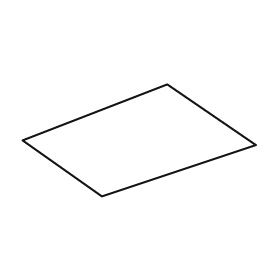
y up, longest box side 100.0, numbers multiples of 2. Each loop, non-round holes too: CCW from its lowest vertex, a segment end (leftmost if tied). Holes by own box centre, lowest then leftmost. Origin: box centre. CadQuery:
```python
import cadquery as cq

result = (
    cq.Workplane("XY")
    .moveTo(-16.0, -24.0)
    .lineTo(50.0, -2.0)
    .lineTo(12.0, 24.0)
    .lineTo(-50.0, 0.0)
    .close()
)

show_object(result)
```